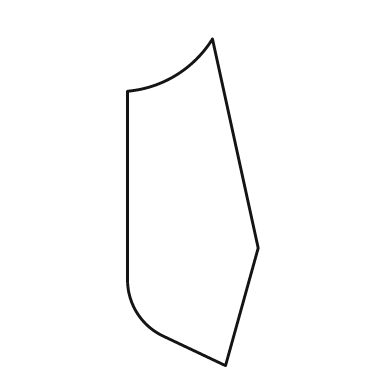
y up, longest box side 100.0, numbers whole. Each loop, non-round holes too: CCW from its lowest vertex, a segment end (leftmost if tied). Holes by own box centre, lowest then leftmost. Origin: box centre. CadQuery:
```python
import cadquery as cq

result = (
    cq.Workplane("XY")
    .moveTo(10.0, -50.0)
    .lineTo(20.0, -14.0)
    .lineTo(6.0, 50.0)
    .threePointArc((-5.0, 39.0), (-20.0, 34.0))
    .lineTo(-20.0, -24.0)
    .threePointArc((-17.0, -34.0), (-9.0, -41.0))
    .close()
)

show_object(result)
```